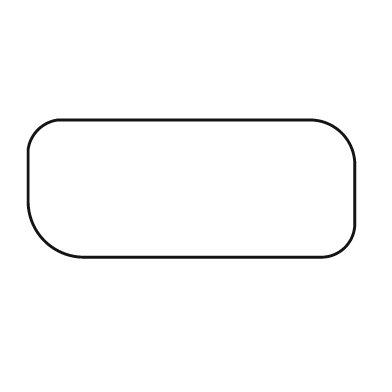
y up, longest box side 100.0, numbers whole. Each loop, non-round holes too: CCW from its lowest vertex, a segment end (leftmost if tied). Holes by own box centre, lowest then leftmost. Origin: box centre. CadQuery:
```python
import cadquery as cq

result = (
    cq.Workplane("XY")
    .moveTo(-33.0, -21.0)
    .lineTo(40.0, -21.0)
    .threePointArc((47.0, -18.0), (50.0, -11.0))
    .lineTo(50.0, 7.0)
    .threePointArc((46.0, 17.0), (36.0, 21.0))
    .lineTo(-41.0, 21.0)
    .threePointArc((-47.0, 18.0), (-50.0, 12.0))
    .lineTo(-50.0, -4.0)
    .threePointArc((-45.0, -16.0), (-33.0, -21.0))
    .close()
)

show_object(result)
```